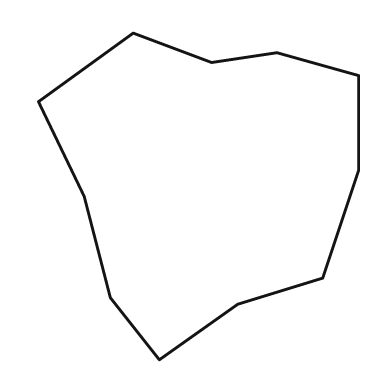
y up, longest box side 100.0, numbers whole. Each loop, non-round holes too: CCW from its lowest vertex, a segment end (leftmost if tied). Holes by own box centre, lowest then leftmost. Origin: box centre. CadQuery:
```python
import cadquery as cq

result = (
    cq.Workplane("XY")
    .moveTo(-12.0, -50.0)
    .lineTo(12.0, -33.0)
    .lineTo(38.0, -25.0)
    .lineTo(49.0, 8.0)
    .lineTo(49.0, 37.0)
    .lineTo(24.0, 44.0)
    .lineTo(4.0, 41.0)
    .lineTo(-20.0, 50.0)
    .lineTo(-49.0, 29.0)
    .lineTo(-35.0, 0.0)
    .lineTo(-27.0, -31.0)
    .close()
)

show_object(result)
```